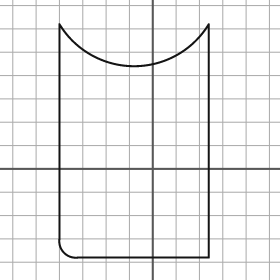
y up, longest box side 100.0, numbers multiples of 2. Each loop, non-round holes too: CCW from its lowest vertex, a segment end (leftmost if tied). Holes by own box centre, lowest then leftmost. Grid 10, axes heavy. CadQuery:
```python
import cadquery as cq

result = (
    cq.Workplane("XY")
    .moveTo(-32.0, -38.0)
    .lineTo(24.0, -38.0)
    .lineTo(24.0, 62.0)
    .threePointArc((-8.0, 44.0), (-40.0, 62.0))
    .lineTo(-40.0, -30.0)
    .threePointArc((-38.0, -36.0), (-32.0, -38.0))
    .close()
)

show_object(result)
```